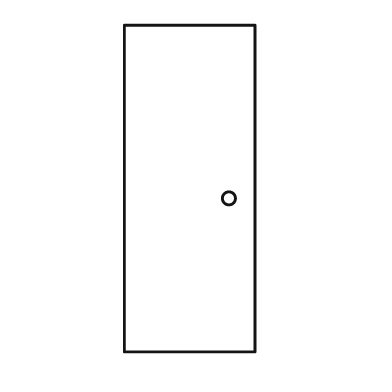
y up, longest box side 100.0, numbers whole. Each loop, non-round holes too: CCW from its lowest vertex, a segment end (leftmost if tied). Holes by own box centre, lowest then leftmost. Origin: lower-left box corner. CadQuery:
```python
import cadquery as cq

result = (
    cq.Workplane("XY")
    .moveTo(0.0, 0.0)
    .lineTo(40.0, 0.0)
    .lineTo(40.0, 100.0)
    .lineTo(0.0, 100.0)
    .close()
    .moveTo(32.0, 47.0)
    .circle(2.0)
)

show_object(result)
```